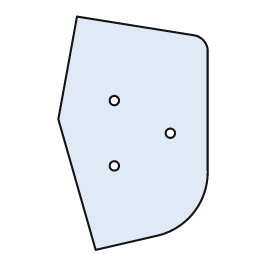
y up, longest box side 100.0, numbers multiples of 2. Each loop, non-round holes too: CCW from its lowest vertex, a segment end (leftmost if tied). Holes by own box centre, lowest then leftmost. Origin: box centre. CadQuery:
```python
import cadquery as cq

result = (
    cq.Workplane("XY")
    .moveTo(-16.0, -50.0)
    .lineTo(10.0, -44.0)
    .threePointArc((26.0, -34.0), (32.0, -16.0))
    .lineTo(32.0, 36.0)
    .threePointArc((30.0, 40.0), (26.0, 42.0))
    .lineTo(-24.0, 50.0)
    .lineTo(-32.0, 6.0)
    .close()
    .moveTo(-8.0, -14.0)
    .circle(2.0)
    .moveTo(16.0, 0.0)
    .circle(2.0)
    .moveTo(-8.0, 14.0)
    .circle(2.0)
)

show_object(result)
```